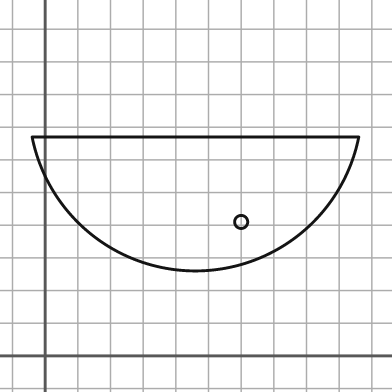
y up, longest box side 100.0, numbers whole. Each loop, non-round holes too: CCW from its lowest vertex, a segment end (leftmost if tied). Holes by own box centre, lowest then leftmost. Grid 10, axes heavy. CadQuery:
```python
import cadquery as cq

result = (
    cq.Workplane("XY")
    .moveTo(-4.0, 67.0)
    .threePointArc((46.0, 26.0), (96.0, 67.0))
    .close()
    .moveTo(60.0, 41.0)
    .circle(2.0)
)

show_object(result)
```